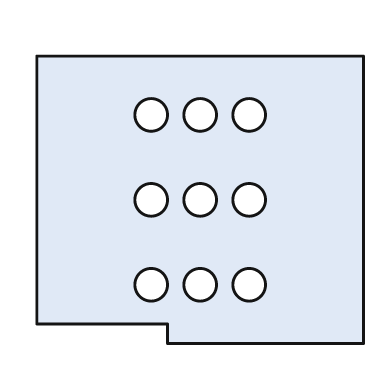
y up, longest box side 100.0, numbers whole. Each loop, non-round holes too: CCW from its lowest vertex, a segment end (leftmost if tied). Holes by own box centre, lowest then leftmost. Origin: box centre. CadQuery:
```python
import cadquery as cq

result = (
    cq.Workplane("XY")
    .moveTo(-10.0, -44.0)
    .lineTo(50.0, -44.0)
    .lineTo(50.0, 44.0)
    .lineTo(-50.0, 44.0)
    .lineTo(-50.0, -38.0)
    .lineTo(-10.0, -38.0)
    .close()
    .moveTo(-15.0, -26.0)
    .circle(5.0)
    .moveTo(0.0, -26.0)
    .circle(5.0)
    .moveTo(15.0, -26.0)
    .circle(5.0)
    .moveTo(-15.0, 0.0)
    .circle(5.0)
    .moveTo(0.0, 0.0)
    .circle(5.0)
    .moveTo(15.0, 0.0)
    .circle(5.0)
    .moveTo(-15.0, 26.0)
    .circle(5.0)
    .moveTo(0.0, 26.0)
    .circle(5.0)
    .moveTo(15.0, 26.0)
    .circle(5.0)
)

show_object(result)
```